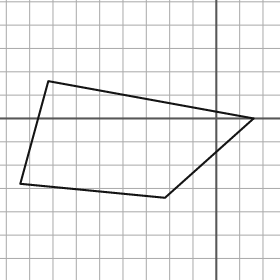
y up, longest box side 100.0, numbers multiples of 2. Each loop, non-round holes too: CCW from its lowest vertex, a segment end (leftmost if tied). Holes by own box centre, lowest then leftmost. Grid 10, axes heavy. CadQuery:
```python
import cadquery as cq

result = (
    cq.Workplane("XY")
    .moveTo(-22.0, -34.0)
    .lineTo(16.0, 0.0)
    .lineTo(-72.0, 16.0)
    .lineTo(-84.0, -28.0)
    .close()
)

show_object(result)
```